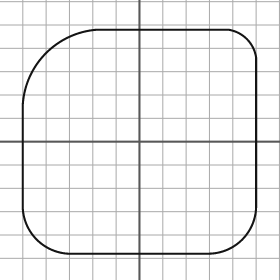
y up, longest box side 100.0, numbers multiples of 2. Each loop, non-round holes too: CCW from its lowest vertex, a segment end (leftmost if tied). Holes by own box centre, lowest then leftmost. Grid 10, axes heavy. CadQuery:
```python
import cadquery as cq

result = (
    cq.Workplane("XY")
    .moveTo(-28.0, -48.0)
    .lineTo(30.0, -48.0)
    .threePointArc((44.0, -42.0), (50.0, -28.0))
    .lineTo(50.0, 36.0)
    .threePointArc((46.0, 44.0), (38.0, 48.0))
    .lineTo(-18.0, 48.0)
    .threePointArc((-40.0, 38.0), (-50.0, 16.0))
    .lineTo(-50.0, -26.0)
    .threePointArc((-44.0, -42.0), (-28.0, -48.0))
    .close()
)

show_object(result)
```